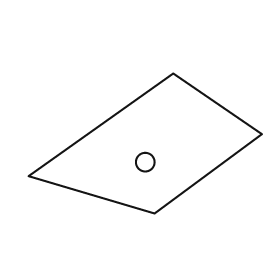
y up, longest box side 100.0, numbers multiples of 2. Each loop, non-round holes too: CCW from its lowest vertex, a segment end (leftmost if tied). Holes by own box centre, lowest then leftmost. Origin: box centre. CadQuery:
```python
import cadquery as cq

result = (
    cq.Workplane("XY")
    .moveTo(4.0, -30.0)
    .lineTo(50.0, 4.0)
    .lineTo(12.0, 30.0)
    .lineTo(-50.0, -14.0)
    .close()
    .moveTo(0.0, -8.0)
    .circle(4.0)
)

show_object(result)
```